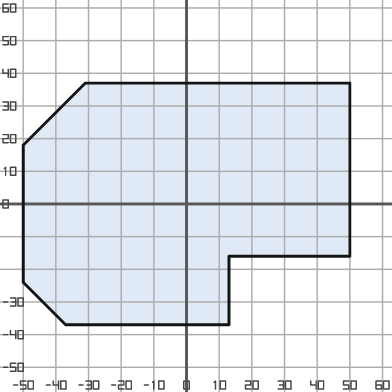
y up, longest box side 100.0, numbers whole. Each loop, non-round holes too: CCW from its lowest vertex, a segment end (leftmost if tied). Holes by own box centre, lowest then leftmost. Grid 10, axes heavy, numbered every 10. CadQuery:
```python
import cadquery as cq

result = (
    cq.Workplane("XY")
    .moveTo(-37.0, -37.0)
    .lineTo(13.0, -37.0)
    .lineTo(13.0, -16.0)
    .lineTo(50.0, -16.0)
    .lineTo(50.0, 37.0)
    .lineTo(-31.0, 37.0)
    .lineTo(-50.0, 18.0)
    .lineTo(-50.0, -24.0)
    .close()
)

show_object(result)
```